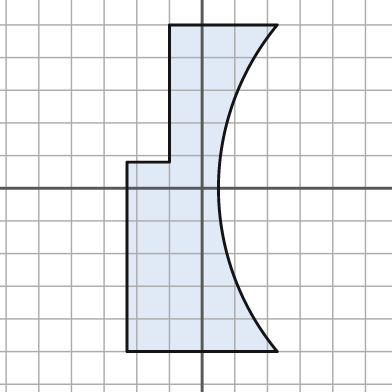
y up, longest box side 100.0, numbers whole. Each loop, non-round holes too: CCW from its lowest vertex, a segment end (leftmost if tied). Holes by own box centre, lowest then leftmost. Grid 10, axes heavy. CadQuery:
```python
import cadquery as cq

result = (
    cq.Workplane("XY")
    .moveTo(-23.0, -50.0)
    .lineTo(23.0, -50.0)
    .threePointArc((5.0, 0.0), (23.0, 50.0))
    .lineTo(-10.0, 50.0)
    .lineTo(-10.0, 8.0)
    .lineTo(-23.0, 8.0)
    .close()
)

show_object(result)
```